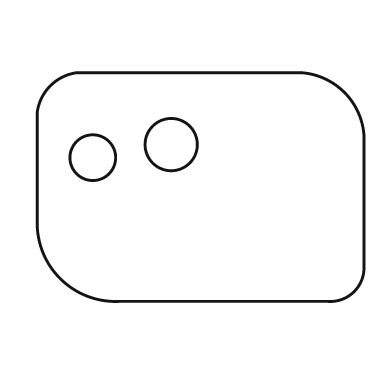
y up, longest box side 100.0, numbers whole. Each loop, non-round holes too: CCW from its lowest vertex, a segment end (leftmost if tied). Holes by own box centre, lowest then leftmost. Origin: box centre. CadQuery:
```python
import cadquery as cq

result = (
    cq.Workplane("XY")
    .moveTo(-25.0, -35.0)
    .lineTo(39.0, -35.0)
    .threePointArc((47.0, -32.0), (50.0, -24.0))
    .lineTo(50.0, 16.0)
    .threePointArc((44.0, 29.0), (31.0, 35.0))
    .lineTo(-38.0, 35.0)
    .threePointArc((-46.0, 31.0), (-50.0, 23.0))
    .lineTo(-50.0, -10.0)
    .threePointArc((-43.0, -28.0), (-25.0, -35.0))
    .close()
    .moveTo(-33.0, 9.0)
    .circle(7.0)
    .moveTo(-9.0, 13.0)
    .circle(8.0)
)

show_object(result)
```